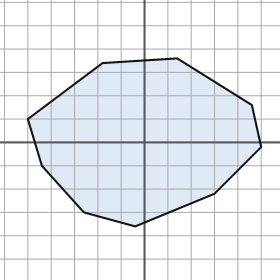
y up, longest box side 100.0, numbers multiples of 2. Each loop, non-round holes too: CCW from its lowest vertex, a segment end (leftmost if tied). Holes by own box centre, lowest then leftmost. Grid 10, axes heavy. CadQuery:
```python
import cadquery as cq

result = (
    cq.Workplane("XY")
    .moveTo(-4.0, -36.0)
    .lineTo(30.0, -22.0)
    .lineTo(50.0, -2.0)
    .lineTo(46.0, 16.0)
    .lineTo(14.0, 36.0)
    .lineTo(-18.0, 34.0)
    .lineTo(-50.0, 10.0)
    .lineTo(-44.0, -10.0)
    .lineTo(-26.0, -30.0)
    .close()
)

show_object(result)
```